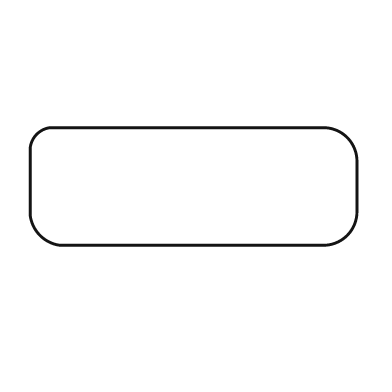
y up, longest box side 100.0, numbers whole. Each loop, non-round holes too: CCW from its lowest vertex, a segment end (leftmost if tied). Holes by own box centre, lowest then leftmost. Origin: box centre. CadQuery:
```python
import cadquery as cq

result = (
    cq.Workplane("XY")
    .moveTo(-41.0, -18.0)
    .lineTo(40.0, -18.0)
    .threePointArc((47.0, -15.0), (50.0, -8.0))
    .lineTo(50.0, 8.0)
    .threePointArc((47.0, 15.0), (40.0, 18.0))
    .lineTo(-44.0, 18.0)
    .threePointArc((-48.0, 16.0), (-50.0, 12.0))
    .lineTo(-50.0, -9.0)
    .threePointArc((-47.0, -15.0), (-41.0, -18.0))
    .close()
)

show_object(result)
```